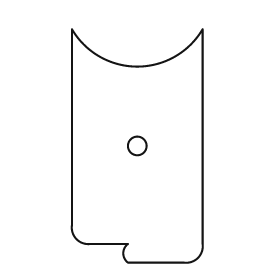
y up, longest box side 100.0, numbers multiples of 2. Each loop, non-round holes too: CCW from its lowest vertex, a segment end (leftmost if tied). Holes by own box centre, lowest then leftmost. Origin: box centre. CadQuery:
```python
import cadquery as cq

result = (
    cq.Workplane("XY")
    .moveTo(-4.0, -50.0)
    .lineTo(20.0, -50.0)
    .threePointArc((26.0, -48.0), (28.0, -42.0))
    .lineTo(28.0, 50.0)
    .threePointArc((0.0, 34.0), (-28.0, 50.0))
    .lineTo(-28.0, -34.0)
    .threePointArc((-26.0, -40.0), (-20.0, -42.0))
    .lineTo(-4.0, -42.0)
    .threePointArc((-6.0, -46.0), (-4.0, -50.0))
    .close()
    .moveTo(0.0, 0.0)
    .circle(4.0)
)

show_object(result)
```